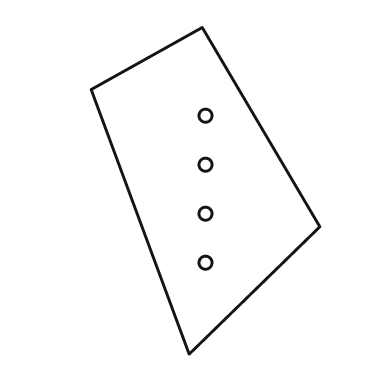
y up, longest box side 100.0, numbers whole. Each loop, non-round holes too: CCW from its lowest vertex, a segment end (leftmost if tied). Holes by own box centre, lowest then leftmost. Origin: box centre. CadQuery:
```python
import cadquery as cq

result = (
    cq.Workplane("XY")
    .moveTo(-5.0, -50.0)
    .lineTo(35.0, -11.0)
    .lineTo(-1.0, 50.0)
    .lineTo(-35.0, 31.0)
    .close()
    .moveTo(0.0, -22.0)
    .circle(2.0)
    .moveTo(0.0, -7.0)
    .circle(2.0)
    .moveTo(0.0, 8.0)
    .circle(2.0)
    .moveTo(0.0, 23.0)
    .circle(2.0)
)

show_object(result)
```